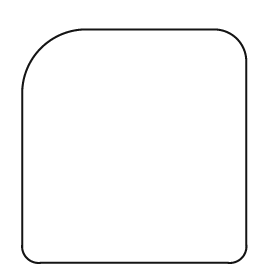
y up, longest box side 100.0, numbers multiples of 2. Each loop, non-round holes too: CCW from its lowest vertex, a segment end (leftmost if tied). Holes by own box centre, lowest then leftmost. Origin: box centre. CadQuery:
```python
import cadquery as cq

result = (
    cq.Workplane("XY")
    .moveTo(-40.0, -50.0)
    .lineTo(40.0, -50.0)
    .threePointArc((46.0, -48.0), (48.0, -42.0))
    .lineTo(48.0, 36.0)
    .threePointArc((44.0, 46.0), (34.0, 50.0))
    .lineTo(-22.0, 50.0)
    .threePointArc((-40.0, 42.0), (-48.0, 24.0))
    .lineTo(-48.0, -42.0)
    .threePointArc((-46.0, -48.0), (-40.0, -50.0))
    .close()
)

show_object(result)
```